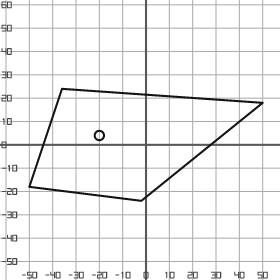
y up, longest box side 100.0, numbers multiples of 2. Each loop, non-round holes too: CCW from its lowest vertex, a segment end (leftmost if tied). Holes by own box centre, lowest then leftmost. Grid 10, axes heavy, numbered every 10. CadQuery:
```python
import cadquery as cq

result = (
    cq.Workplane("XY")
    .moveTo(-2.0, -24.0)
    .lineTo(50.0, 18.0)
    .lineTo(-36.0, 24.0)
    .lineTo(-50.0, -18.0)
    .close()
    .moveTo(-20.0, 4.0)
    .circle(2.0)
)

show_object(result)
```